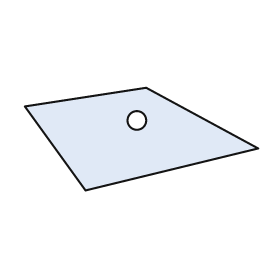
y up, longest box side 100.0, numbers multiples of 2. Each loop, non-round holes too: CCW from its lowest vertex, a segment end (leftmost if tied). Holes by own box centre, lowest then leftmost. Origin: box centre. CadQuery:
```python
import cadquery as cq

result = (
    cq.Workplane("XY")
    .moveTo(-24.0, -22.0)
    .lineTo(50.0, -4.0)
    .lineTo(2.0, 22.0)
    .lineTo(-50.0, 14.0)
    .close()
    .moveTo(-2.0, 8.0)
    .circle(4.0)
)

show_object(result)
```